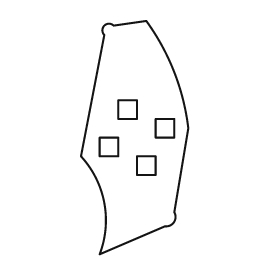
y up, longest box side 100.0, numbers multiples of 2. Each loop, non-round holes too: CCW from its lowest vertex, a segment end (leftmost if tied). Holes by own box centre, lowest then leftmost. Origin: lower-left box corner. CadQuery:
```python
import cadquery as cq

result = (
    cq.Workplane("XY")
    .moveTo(8.0, 0.0)
    .lineTo(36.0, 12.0)
    .threePointArc((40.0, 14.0), (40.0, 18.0))
    .lineTo(46.0, 54.0)
    .threePointArc((40.0, 78.0), (28.0, 100.0))
    .lineTo(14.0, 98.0)
    .threePointArc((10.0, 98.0), (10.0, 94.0))
    .lineTo(0.0, 42.0)
    .threePointArc((10.0, 22.0), (8.0, 0.0))
    .close()
    .moveTo(24.0, 34.0)
    .lineTo(32.0, 34.0)
    .lineTo(32.0, 42.0)
    .lineTo(24.0, 42.0)
    .close()
    .moveTo(8.0, 42.0)
    .lineTo(16.0, 42.0)
    .lineTo(16.0, 50.0)
    .lineTo(8.0, 50.0)
    .close()
    .moveTo(32.0, 50.0)
    .lineTo(40.0, 50.0)
    .lineTo(40.0, 58.0)
    .lineTo(32.0, 58.0)
    .close()
    .moveTo(16.0, 58.0)
    .lineTo(24.0, 58.0)
    .lineTo(24.0, 66.0)
    .lineTo(16.0, 66.0)
    .close()
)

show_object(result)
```